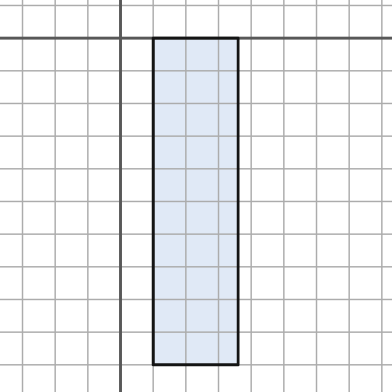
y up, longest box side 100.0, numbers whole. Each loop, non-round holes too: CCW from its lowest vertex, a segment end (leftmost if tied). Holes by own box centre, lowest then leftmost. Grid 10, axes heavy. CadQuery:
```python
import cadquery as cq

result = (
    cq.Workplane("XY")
    .moveTo(10.0, -100.0)
    .lineTo(36.0, -100.0)
    .lineTo(36.0, 0.0)
    .lineTo(10.0, 0.0)
    .close()
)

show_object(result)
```